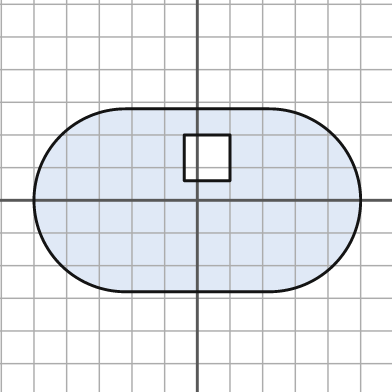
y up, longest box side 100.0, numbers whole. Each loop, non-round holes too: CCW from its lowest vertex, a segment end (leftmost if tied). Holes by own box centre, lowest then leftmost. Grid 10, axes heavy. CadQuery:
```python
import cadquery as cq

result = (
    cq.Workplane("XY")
    .moveTo(-22.0, -28.0)
    .lineTo(22.0, -28.0)
    .threePointArc((50.0, 0.0), (22.0, 28.0))
    .lineTo(-22.0, 28.0)
    .threePointArc((-50.0, 0.0), (-22.0, -28.0))
    .close()
    .moveTo(-4.0, 6.0)
    .lineTo(10.0, 6.0)
    .lineTo(10.0, 20.0)
    .lineTo(-4.0, 20.0)
    .close()
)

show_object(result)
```